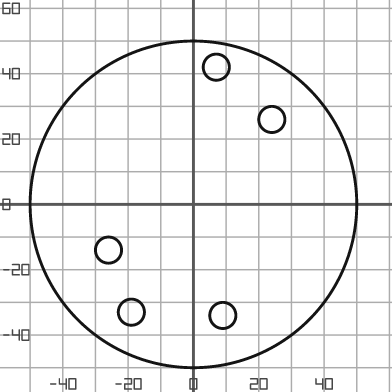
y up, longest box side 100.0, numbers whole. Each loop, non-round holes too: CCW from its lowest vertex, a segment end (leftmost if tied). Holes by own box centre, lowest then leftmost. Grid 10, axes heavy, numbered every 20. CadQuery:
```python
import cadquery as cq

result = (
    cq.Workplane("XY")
    .moveTo(0.0, 0.0)
    .circle(50.0)
    .moveTo(9.0, -34.0)
    .circle(4.0)
    .moveTo(-19.0, -33.0)
    .circle(4.0)
    .moveTo(-26.0, -14.0)
    .circle(4.0)
    .moveTo(24.0, 26.0)
    .circle(4.0)
    .moveTo(7.0, 42.0)
    .circle(4.0)
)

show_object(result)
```